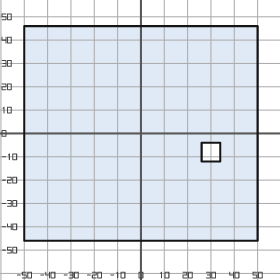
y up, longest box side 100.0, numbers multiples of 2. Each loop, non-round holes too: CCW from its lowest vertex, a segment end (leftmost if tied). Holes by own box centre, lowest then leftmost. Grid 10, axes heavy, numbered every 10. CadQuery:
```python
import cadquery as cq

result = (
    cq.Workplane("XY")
    .moveTo(-50.0, -46.0)
    .lineTo(50.0, -46.0)
    .lineTo(50.0, 46.0)
    .lineTo(-50.0, 46.0)
    .close()
    .moveTo(26.0, -12.0)
    .lineTo(34.0, -12.0)
    .lineTo(34.0, -4.0)
    .lineTo(26.0, -4.0)
    .close()
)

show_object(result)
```